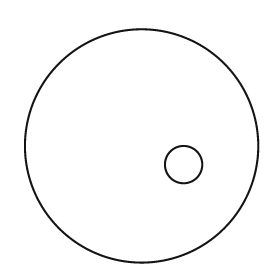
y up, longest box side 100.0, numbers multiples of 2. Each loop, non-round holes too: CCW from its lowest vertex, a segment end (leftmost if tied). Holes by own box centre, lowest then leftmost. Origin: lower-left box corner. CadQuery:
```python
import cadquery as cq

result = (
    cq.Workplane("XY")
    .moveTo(50.0, 50.0)
    .circle(50.0)
    .moveTo(68.0, 42.0)
    .circle(8.0)
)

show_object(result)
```